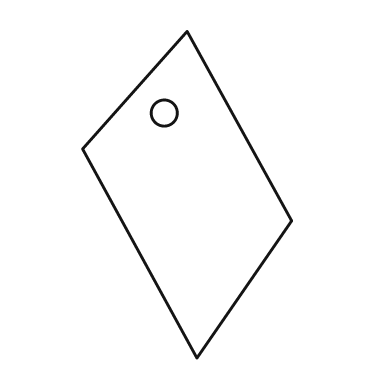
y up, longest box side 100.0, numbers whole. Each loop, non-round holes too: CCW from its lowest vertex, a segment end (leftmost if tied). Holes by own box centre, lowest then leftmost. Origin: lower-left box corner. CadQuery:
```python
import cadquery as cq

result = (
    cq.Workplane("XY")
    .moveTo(35.0, 0.0)
    .lineTo(64.0, 42.0)
    .lineTo(32.0, 100.0)
    .lineTo(0.0, 64.0)
    .close()
    .moveTo(25.0, 75.0)
    .circle(4.0)
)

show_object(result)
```